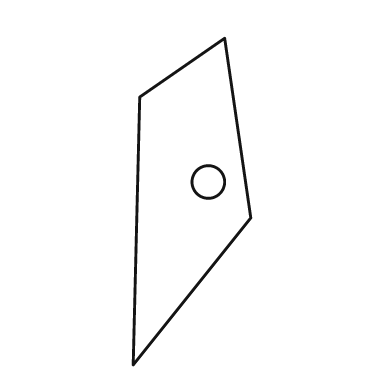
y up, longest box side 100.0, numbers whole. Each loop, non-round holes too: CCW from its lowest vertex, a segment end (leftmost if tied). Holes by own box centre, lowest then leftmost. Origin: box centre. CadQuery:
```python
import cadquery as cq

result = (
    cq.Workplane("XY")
    .moveTo(-18.0, -50.0)
    .lineTo(18.0, -5.0)
    .lineTo(10.0, 50.0)
    .lineTo(-16.0, 32.0)
    .close()
    .moveTo(5.0, 6.0)
    .circle(5.0)
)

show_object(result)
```